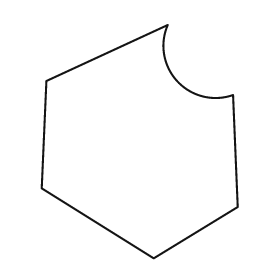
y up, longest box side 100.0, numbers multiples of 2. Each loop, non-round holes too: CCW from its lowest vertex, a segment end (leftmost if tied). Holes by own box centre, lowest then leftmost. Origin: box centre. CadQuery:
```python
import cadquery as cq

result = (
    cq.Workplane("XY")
    .moveTo(6.0, -50.0)
    .lineTo(42.0, -28.0)
    .lineTo(40.0, 20.0)
    .threePointArc((16.0, 26.0), (12.0, 50.0))
    .lineTo(-40.0, 26.0)
    .lineTo(-42.0, -20.0)
    .close()
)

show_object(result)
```